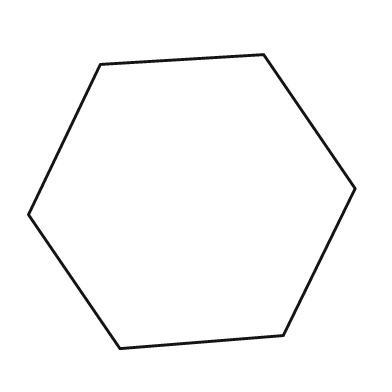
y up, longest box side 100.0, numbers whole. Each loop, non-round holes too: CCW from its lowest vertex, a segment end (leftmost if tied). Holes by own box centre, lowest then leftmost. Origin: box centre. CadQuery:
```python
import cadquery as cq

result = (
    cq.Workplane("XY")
    .moveTo(-22.0, -45.0)
    .lineTo(28.0, -41.0)
    .lineTo(50.0, 4.0)
    .lineTo(22.0, 45.0)
    .lineTo(-28.0, 42.0)
    .lineTo(-50.0, -4.0)
    .close()
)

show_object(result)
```